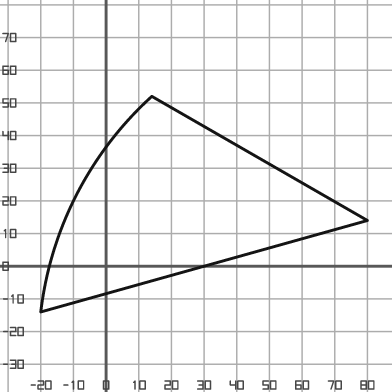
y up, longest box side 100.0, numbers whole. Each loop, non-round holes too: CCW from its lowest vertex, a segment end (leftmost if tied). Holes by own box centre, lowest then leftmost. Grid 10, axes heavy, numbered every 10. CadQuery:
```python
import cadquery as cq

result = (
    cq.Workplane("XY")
    .moveTo(-20.0, -14.0)
    .lineTo(80.0, 14.0)
    .lineTo(14.0, 52.0)
    .threePointArc((-9.0, 22.0), (-20.0, -14.0))
    .close()
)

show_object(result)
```